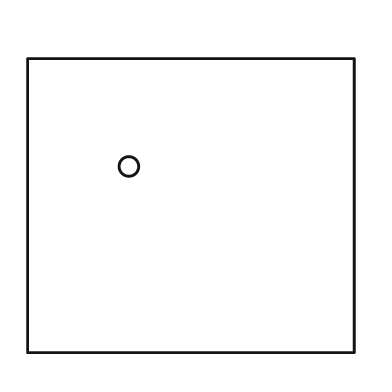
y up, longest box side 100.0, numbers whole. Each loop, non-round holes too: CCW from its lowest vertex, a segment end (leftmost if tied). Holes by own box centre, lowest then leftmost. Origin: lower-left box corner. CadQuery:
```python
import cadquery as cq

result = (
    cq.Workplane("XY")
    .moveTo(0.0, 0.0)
    .lineTo(100.0, 0.0)
    .lineTo(100.0, 90.0)
    .lineTo(0.0, 90.0)
    .close()
    .moveTo(31.0, 57.0)
    .circle(3.0)
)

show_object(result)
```